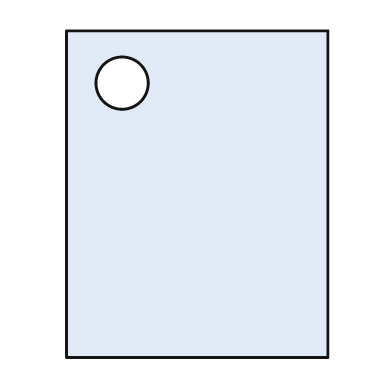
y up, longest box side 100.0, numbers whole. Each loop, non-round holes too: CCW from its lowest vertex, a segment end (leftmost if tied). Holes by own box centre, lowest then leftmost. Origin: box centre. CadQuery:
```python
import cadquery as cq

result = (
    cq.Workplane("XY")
    .moveTo(-40.0, -50.0)
    .lineTo(40.0, -50.0)
    .lineTo(40.0, 50.0)
    .lineTo(-40.0, 50.0)
    .close()
    .moveTo(-23.0, 34.0)
    .circle(8.0)
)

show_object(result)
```